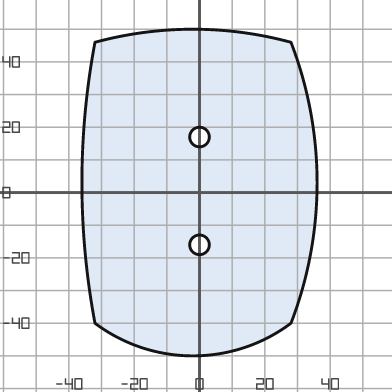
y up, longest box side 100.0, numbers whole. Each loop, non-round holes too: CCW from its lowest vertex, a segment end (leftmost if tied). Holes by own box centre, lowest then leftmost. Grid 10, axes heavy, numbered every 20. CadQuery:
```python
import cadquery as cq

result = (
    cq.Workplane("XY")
    .moveTo(-32.0, -40.0)
    .threePointArc((-2.0, -50.0), (28.0, -40.0))
    .threePointArc((36.0, 3.0), (28.0, 46.0))
    .threePointArc((-2.0, 50.0), (-32.0, 46.0))
    .threePointArc((-36.0, 3.0), (-32.0, -40.0))
    .close()
    .moveTo(0.0, -16.0)
    .circle(3.0)
    .moveTo(0.0, 17.0)
    .circle(3.0)
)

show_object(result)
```